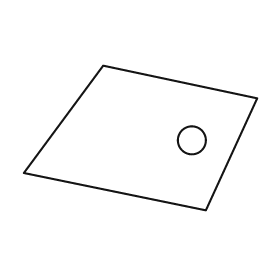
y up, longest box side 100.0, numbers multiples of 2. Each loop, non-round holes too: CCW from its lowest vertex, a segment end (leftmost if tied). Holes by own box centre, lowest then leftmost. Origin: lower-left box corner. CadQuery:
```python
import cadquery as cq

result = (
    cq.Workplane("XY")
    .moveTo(78.0, 0.0)
    .lineTo(100.0, 48.0)
    .lineTo(34.0, 62.0)
    .lineTo(0.0, 16.0)
    .close()
    .moveTo(72.0, 30.0)
    .circle(6.0)
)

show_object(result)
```